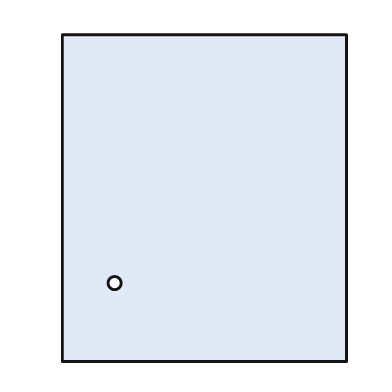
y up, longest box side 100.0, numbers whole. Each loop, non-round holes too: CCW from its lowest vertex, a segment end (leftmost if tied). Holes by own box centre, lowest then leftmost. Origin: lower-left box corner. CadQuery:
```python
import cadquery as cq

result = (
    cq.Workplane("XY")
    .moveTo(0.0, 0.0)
    .lineTo(87.0, 0.0)
    .lineTo(87.0, 100.0)
    .lineTo(0.0, 100.0)
    .close()
    .moveTo(16.0, 24.0)
    .circle(2.0)
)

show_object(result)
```